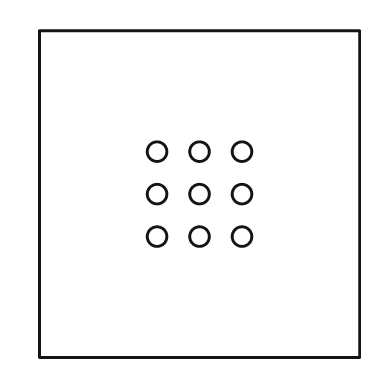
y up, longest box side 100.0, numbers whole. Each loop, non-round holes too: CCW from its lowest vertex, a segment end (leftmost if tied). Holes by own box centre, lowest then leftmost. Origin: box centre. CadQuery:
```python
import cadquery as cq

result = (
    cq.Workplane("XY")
    .moveTo(-49.0, -50.0)
    .lineTo(49.0, -50.0)
    .lineTo(49.0, 50.0)
    .lineTo(-49.0, 50.0)
    .close()
    .moveTo(-13.0, -13.0)
    .circle(3.0)
    .moveTo(0.0, -13.0)
    .circle(3.0)
    .moveTo(13.0, -13.0)
    .circle(3.0)
    .moveTo(-13.0, 0.0)
    .circle(3.0)
    .moveTo(0.0, 0.0)
    .circle(3.0)
    .moveTo(13.0, 0.0)
    .circle(3.0)
    .moveTo(-13.0, 13.0)
    .circle(3.0)
    .moveTo(0.0, 13.0)
    .circle(3.0)
    .moveTo(13.0, 13.0)
    .circle(3.0)
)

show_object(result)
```